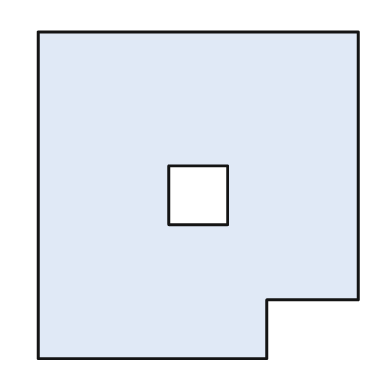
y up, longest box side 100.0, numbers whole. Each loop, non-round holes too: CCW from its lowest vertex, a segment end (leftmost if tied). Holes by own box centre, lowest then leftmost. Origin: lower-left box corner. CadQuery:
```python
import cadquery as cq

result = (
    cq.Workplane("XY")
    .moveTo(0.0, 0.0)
    .lineTo(70.0, 0.0)
    .lineTo(70.0, 18.0)
    .lineTo(98.0, 18.0)
    .lineTo(98.0, 100.0)
    .lineTo(0.0, 100.0)
    .close()
    .moveTo(40.0, 41.0)
    .lineTo(58.0, 41.0)
    .lineTo(58.0, 59.0)
    .lineTo(40.0, 59.0)
    .close()
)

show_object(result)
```